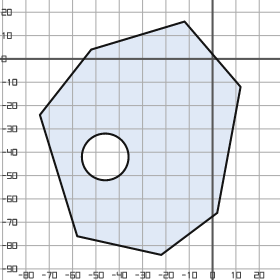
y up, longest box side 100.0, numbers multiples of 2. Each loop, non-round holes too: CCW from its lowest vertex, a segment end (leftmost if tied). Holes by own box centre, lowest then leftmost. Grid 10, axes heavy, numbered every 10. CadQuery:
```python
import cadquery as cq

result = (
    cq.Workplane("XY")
    .moveTo(-22.0, -84.0)
    .lineTo(2.0, -66.0)
    .lineTo(12.0, -12.0)
    .lineTo(-12.0, 16.0)
    .lineTo(-52.0, 4.0)
    .lineTo(-74.0, -24.0)
    .lineTo(-58.0, -76.0)
    .close()
    .moveTo(-46.0, -42.0)
    .circle(10.0)
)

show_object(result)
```